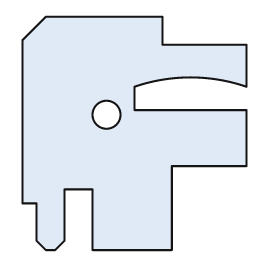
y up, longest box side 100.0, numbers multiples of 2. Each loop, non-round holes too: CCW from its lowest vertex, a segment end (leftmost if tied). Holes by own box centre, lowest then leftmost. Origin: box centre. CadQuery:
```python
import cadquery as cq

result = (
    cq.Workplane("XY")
    .moveTo(-38.0, -50.0)
    .lineTo(-34.0, -50.0)
    .lineTo(-30.0, -46.0)
    .lineTo(-30.0, -24.0)
    .lineTo(-18.0, -24.0)
    .lineTo(-18.0, -50.0)
    .lineTo(16.0, -50.0)
    .lineTo(16.0, -14.0)
    .lineTo(48.0, -14.0)
    .lineTo(48.0, 10.0)
    .lineTo(0.0, 10.0)
    .lineTo(0.0, 20.0)
    .threePointArc((24.0, 24.0), (48.0, 20.0))
    .lineTo(48.0, 38.0)
    .lineTo(12.0, 38.0)
    .lineTo(12.0, 50.0)
    .lineTo(-38.0, 50.0)
    .lineTo(-48.0, 40.0)
    .lineTo(-48.0, -30.0)
    .lineTo(-42.0, -30.0)
    .lineTo(-42.0, -46.0)
    .close()
    .moveTo(-12.0, 8.0)
    .circle(6.0)
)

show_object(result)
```